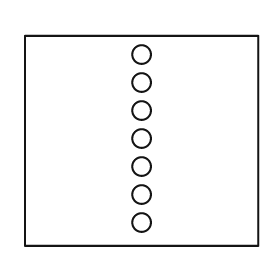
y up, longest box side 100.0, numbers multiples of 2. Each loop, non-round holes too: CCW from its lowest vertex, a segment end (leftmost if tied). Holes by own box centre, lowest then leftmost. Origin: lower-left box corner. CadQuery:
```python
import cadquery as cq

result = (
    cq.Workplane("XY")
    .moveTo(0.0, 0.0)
    .lineTo(100.0, 0.0)
    .lineTo(100.0, 90.0)
    .lineTo(0.0, 90.0)
    .close()
    .moveTo(50.0, 10.0)
    .circle(4.0)
    .moveTo(50.0, 22.0)
    .circle(4.0)
    .moveTo(50.0, 34.0)
    .circle(4.0)
    .moveTo(50.0, 46.0)
    .circle(4.0)
    .moveTo(50.0, 58.0)
    .circle(4.0)
    .moveTo(50.0, 70.0)
    .circle(4.0)
    .moveTo(50.0, 82.0)
    .circle(4.0)
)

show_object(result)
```